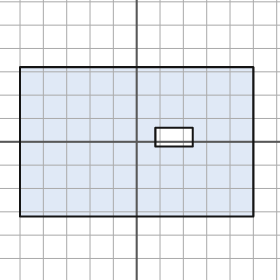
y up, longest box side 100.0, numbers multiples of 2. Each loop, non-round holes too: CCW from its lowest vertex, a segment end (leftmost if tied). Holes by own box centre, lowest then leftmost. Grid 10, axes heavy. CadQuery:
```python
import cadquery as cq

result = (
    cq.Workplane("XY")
    .moveTo(-50.0, -32.0)
    .lineTo(50.0, -32.0)
    .lineTo(50.0, 32.0)
    .lineTo(-50.0, 32.0)
    .close()
    .moveTo(8.0, -2.0)
    .lineTo(24.0, -2.0)
    .lineTo(24.0, 6.0)
    .lineTo(8.0, 6.0)
    .close()
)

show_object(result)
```